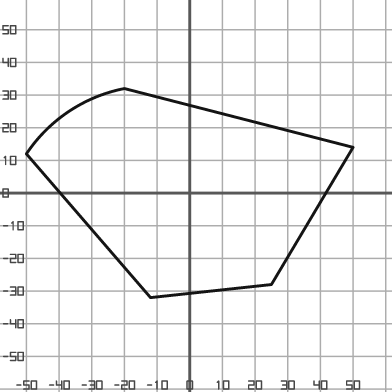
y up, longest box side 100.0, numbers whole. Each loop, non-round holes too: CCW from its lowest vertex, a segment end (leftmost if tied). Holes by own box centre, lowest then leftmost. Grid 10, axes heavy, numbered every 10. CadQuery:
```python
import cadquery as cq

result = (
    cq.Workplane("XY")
    .moveTo(-12.0, -32.0)
    .lineTo(25.0, -28.0)
    .lineTo(50.0, 14.0)
    .lineTo(-20.0, 32.0)
    .threePointArc((-37.0, 25.0), (-50.0, 12.0))
    .close()
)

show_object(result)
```